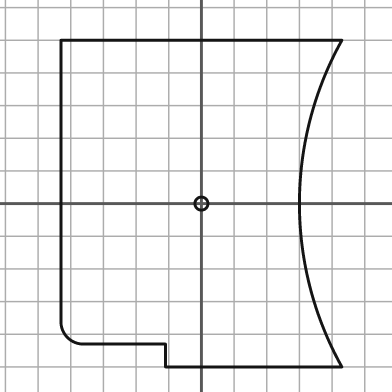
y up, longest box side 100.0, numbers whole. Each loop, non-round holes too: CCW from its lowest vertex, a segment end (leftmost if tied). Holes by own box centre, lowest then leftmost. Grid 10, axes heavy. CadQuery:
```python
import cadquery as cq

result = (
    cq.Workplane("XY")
    .moveTo(-11.0, -50.0)
    .lineTo(43.0, -50.0)
    .threePointArc((30.0, 0.0), (43.0, 50.0))
    .lineTo(-43.0, 50.0)
    .lineTo(-43.0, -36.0)
    .threePointArc((-41.0, -41.0), (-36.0, -43.0))
    .lineTo(-11.0, -43.0)
    .close()
    .moveTo(0.0, 0.0)
    .circle(2.0)
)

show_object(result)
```